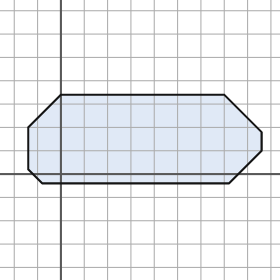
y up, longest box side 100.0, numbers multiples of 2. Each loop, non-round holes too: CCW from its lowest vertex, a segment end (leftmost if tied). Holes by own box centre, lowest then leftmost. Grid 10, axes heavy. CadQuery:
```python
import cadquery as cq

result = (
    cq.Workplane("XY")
    .moveTo(-8.0, -4.0)
    .lineTo(72.0, -4.0)
    .lineTo(86.0, 10.0)
    .lineTo(86.0, 18.0)
    .lineTo(70.0, 34.0)
    .lineTo(0.0, 34.0)
    .lineTo(-14.0, 20.0)
    .lineTo(-14.0, 2.0)
    .close()
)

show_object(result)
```